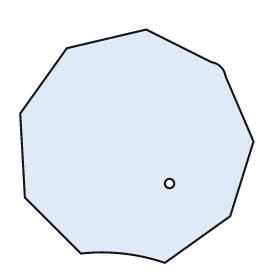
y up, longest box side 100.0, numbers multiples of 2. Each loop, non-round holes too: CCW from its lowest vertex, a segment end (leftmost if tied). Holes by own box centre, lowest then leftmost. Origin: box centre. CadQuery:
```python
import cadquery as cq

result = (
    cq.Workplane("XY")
    .moveTo(12.0, -50.0)
    .lineTo(40.0, -30.0)
    .lineTo(50.0, 2.0)
    .lineTo(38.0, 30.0)
    .threePointArc((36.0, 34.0), (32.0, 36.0))
    .lineTo(4.0, 50.0)
    .lineTo(-30.0, 42.0)
    .lineTo(-50.0, 14.0)
    .lineTo(-48.0, -22.0)
    .lineTo(-24.0, -46.0)
    .threePointArc((-6.0, -46.0), (12.0, -50.0))
    .close()
    .moveTo(14.0, -16.0)
    .circle(2.0)
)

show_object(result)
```